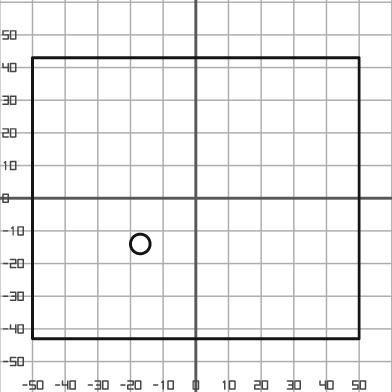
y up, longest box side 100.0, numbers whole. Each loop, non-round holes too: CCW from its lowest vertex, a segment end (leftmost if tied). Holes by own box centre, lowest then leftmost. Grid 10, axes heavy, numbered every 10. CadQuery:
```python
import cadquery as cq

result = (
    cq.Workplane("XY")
    .moveTo(-50.0, -43.0)
    .lineTo(50.0, -43.0)
    .lineTo(50.0, 43.0)
    .lineTo(-50.0, 43.0)
    .close()
    .moveTo(-17.0, -14.0)
    .circle(3.0)
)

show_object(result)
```